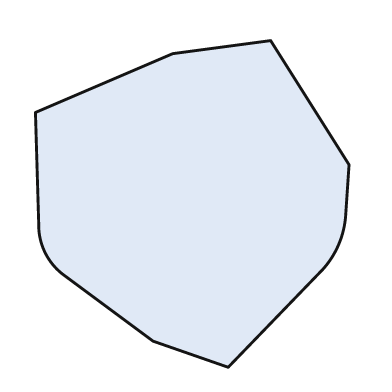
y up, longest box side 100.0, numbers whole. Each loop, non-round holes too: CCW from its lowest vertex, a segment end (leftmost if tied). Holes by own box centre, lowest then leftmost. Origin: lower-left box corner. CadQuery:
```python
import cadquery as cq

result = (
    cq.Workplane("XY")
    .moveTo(59.0, 0.0)
    .lineTo(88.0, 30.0)
    .threePointArc((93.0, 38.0), (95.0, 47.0))
    .lineTo(96.0, 62.0)
    .lineTo(72.0, 100.0)
    .lineTo(42.0, 96.0)
    .lineTo(0.0, 78.0)
    .lineTo(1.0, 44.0)
    .threePointArc((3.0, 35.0), (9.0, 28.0))
    .lineTo(36.0, 8.0)
    .close()
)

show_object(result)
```